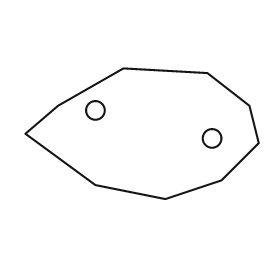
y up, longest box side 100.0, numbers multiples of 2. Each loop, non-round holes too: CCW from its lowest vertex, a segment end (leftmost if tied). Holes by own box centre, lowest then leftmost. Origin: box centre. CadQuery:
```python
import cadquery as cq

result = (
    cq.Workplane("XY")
    .moveTo(10.0, -28.0)
    .lineTo(34.0, -20.0)
    .lineTo(50.0, -4.0)
    .lineTo(46.0, 12.0)
    .lineTo(28.0, 26.0)
    .lineTo(-8.0, 28.0)
    .lineTo(-36.0, 12.0)
    .lineTo(-50.0, 0.0)
    .lineTo(-20.0, -22.0)
    .close()
    .moveTo(30.0, -2.0)
    .circle(4.0)
    .moveTo(-20.0, 10.0)
    .circle(4.0)
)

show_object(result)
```